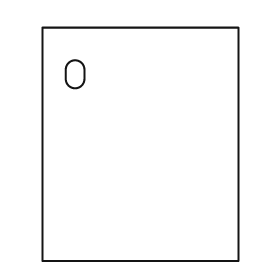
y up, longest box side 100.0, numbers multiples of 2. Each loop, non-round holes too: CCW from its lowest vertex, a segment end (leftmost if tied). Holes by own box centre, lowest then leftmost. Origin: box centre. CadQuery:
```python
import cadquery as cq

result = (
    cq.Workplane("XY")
    .moveTo(-42.0, -50.0)
    .lineTo(42.0, -50.0)
    .lineTo(42.0, 50.0)
    .lineTo(-42.0, 50.0)
    .close()
    .moveTo(-32.0, 28.0)
    .threePointArc((-28.0, 24.0), (-24.0, 28.0))
    .lineTo(-24.0, 32.0)
    .threePointArc((-28.0, 36.0), (-32.0, 32.0))
    .close()
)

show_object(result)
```